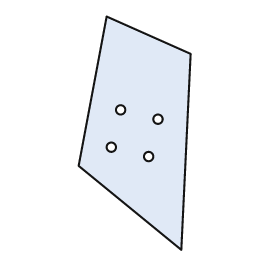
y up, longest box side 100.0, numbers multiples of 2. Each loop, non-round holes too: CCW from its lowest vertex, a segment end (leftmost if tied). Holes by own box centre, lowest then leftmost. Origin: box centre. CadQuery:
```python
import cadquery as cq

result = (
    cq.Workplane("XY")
    .moveTo(20.0, -50.0)
    .lineTo(24.0, 34.0)
    .lineTo(-12.0, 50.0)
    .lineTo(-24.0, -14.0)
    .close()
    .moveTo(6.0, -10.0)
    .circle(2.0)
    .moveTo(-10.0, -6.0)
    .circle(2.0)
    .moveTo(10.0, 6.0)
    .circle(2.0)
    .moveTo(-6.0, 10.0)
    .circle(2.0)
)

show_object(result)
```